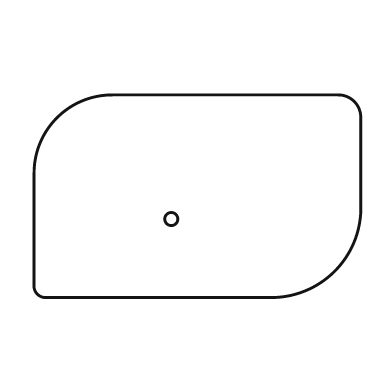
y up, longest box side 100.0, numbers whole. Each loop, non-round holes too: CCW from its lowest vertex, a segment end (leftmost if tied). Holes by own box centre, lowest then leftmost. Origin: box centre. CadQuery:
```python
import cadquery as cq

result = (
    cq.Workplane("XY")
    .moveTo(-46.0, -31.0)
    .lineTo(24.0, -31.0)
    .threePointArc((42.0, -23.0), (50.0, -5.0))
    .lineTo(50.0, 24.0)
    .threePointArc((48.0, 29.0), (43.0, 31.0))
    .lineTo(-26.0, 31.0)
    .threePointArc((-43.0, 24.0), (-50.0, 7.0))
    .lineTo(-50.0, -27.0)
    .threePointArc((-49.0, -30.0), (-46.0, -31.0))
    .close()
    .moveTo(-8.0, -7.0)
    .circle(2.0)
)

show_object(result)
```